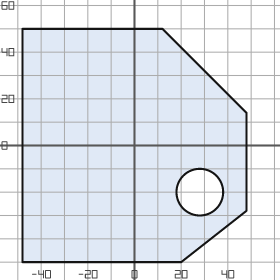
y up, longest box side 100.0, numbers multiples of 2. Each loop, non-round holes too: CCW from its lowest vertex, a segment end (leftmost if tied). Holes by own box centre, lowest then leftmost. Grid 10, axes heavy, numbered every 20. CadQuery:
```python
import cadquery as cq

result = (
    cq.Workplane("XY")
    .moveTo(-48.0, -50.0)
    .lineTo(20.0, -50.0)
    .lineTo(48.0, -28.0)
    .lineTo(48.0, 14.0)
    .lineTo(12.0, 50.0)
    .lineTo(-48.0, 50.0)
    .close()
    .moveTo(28.0, -20.0)
    .circle(10.0)
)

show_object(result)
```